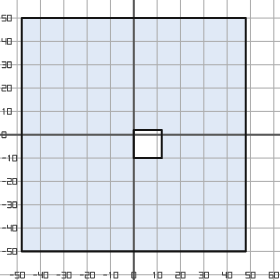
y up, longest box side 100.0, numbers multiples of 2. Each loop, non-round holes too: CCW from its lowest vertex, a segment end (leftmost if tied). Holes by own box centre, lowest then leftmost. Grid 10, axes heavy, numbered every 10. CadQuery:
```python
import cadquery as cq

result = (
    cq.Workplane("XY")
    .moveTo(-48.0, -50.0)
    .lineTo(48.0, -50.0)
    .lineTo(48.0, 50.0)
    .lineTo(-48.0, 50.0)
    .close()
    .moveTo(0.0, -10.0)
    .lineTo(12.0, -10.0)
    .lineTo(12.0, 2.0)
    .lineTo(0.0, 2.0)
    .close()
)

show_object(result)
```